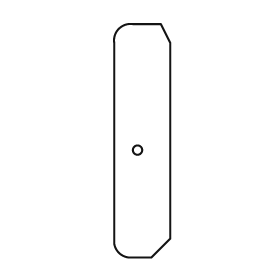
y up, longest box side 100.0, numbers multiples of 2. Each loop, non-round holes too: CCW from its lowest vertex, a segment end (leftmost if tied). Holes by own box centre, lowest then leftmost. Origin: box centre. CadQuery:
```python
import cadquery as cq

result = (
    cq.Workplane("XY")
    .moveTo(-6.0, -50.0)
    .lineTo(4.0, -50.0)
    .lineTo(12.0, -42.0)
    .lineTo(12.0, 42.0)
    .lineTo(8.0, 50.0)
    .lineTo(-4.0, 50.0)
    .threePointArc((-10.0, 48.0), (-12.0, 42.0))
    .lineTo(-12.0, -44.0)
    .threePointArc((-10.0, -48.0), (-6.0, -50.0))
    .close()
    .moveTo(-2.0, -4.0)
    .circle(2.0)
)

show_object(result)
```